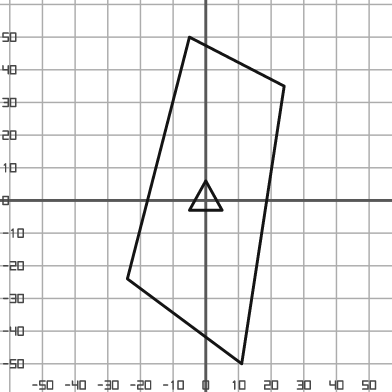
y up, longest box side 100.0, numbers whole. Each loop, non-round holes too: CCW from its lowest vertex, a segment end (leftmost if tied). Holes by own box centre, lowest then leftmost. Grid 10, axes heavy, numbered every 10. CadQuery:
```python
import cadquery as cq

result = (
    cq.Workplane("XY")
    .moveTo(11.0, -50.0)
    .lineTo(24.0, 35.0)
    .lineTo(-5.0, 50.0)
    .lineTo(-24.0, -24.0)
    .close()
    .moveTo(-5.0, -3.0)
    .lineTo(5.0, -3.0)
    .lineTo(0.0, 6.0)
    .close()
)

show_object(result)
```